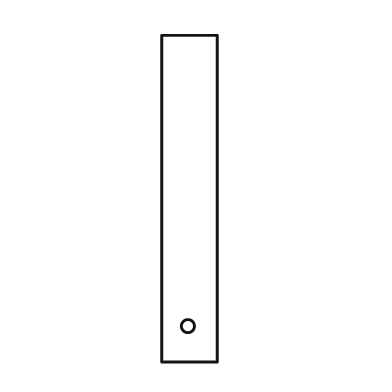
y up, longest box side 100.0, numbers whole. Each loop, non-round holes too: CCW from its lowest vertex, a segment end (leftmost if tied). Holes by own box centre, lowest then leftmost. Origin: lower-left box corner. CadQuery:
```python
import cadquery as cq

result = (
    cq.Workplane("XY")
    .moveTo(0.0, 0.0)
    .lineTo(17.0, 0.0)
    .lineTo(17.0, 100.0)
    .lineTo(0.0, 100.0)
    .close()
    .moveTo(8.0, 11.0)
    .circle(2.0)
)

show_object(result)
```